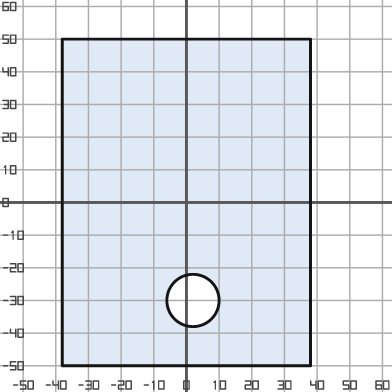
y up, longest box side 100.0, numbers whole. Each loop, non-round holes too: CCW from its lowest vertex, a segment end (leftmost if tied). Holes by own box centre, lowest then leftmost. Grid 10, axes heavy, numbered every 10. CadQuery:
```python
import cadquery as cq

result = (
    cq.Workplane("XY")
    .moveTo(-38.0, -50.0)
    .lineTo(38.0, -50.0)
    .lineTo(38.0, 50.0)
    .lineTo(-38.0, 50.0)
    .close()
    .moveTo(2.0, -30.0)
    .circle(8.0)
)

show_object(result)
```